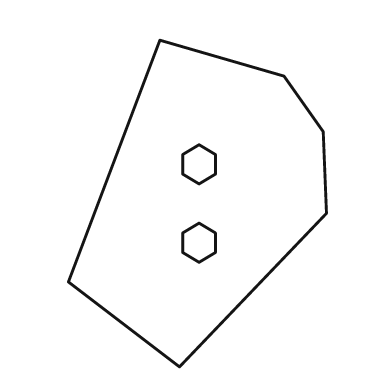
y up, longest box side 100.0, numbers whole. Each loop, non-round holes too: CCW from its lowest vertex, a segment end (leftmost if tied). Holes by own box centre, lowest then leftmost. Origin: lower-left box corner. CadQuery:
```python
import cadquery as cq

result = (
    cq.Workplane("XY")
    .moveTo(34.0, 0.0)
    .lineTo(79.0, 47.0)
    .lineTo(78.0, 72.0)
    .lineTo(66.0, 89.0)
    .lineTo(28.0, 100.0)
    .lineTo(0.0, 26.0)
    .close()
    .moveTo(40.0, 32.0)
    .lineTo(45.0, 35.0)
    .lineTo(45.0, 41.0)
    .lineTo(40.0, 44.0)
    .lineTo(35.0, 41.0)
    .lineTo(35.0, 35.0)
    .close()
    .moveTo(40.0, 56.0)
    .lineTo(45.0, 59.0)
    .lineTo(45.0, 65.0)
    .lineTo(40.0, 68.0)
    .lineTo(35.0, 65.0)
    .lineTo(35.0, 59.0)
    .close()
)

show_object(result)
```